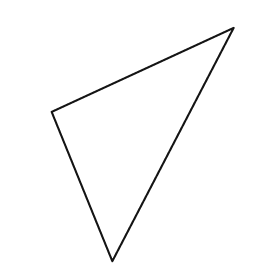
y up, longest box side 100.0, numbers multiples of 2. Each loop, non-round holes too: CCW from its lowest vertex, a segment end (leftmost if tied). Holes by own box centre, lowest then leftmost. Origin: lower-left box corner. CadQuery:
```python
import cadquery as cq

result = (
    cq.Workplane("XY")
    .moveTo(26.0, 0.0)
    .lineTo(78.0, 100.0)
    .lineTo(0.0, 64.0)
    .close()
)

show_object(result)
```